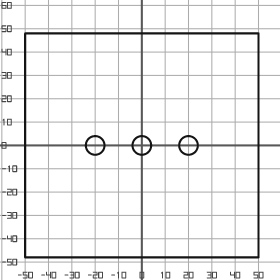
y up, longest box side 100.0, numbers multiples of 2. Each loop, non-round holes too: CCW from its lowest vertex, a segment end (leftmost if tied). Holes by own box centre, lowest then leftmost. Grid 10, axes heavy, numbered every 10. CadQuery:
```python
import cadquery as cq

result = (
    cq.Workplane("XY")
    .moveTo(-50.0, -48.0)
    .lineTo(50.0, -48.0)
    .lineTo(50.0, 48.0)
    .lineTo(-50.0, 48.0)
    .close()
    .moveTo(-20.0, 0.0)
    .circle(4.0)
    .moveTo(0.0, 0.0)
    .circle(4.0)
    .moveTo(20.0, 0.0)
    .circle(4.0)
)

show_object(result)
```